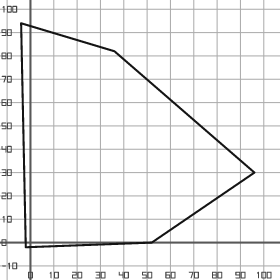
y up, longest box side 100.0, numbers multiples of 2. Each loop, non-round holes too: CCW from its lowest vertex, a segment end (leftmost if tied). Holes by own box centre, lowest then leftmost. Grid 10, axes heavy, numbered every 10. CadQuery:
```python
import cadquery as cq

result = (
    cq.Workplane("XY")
    .moveTo(-2.0, -2.0)
    .lineTo(52.0, 0.0)
    .lineTo(96.0, 30.0)
    .lineTo(36.0, 82.0)
    .lineTo(-4.0, 94.0)
    .close()
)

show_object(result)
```